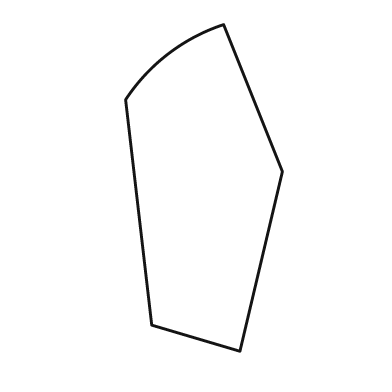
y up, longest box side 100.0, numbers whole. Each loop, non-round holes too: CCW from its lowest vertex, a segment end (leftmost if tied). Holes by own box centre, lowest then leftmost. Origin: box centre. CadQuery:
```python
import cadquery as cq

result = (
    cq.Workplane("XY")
    .moveTo(11.0, -50.0)
    .lineTo(24.0, 5.0)
    .lineTo(6.0, 50.0)
    .threePointArc((-11.0, 41.0), (-24.0, 27.0))
    .lineTo(-16.0, -42.0)
    .close()
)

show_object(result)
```